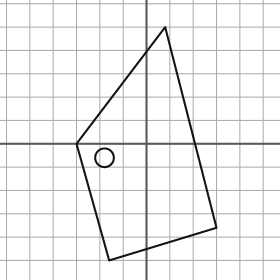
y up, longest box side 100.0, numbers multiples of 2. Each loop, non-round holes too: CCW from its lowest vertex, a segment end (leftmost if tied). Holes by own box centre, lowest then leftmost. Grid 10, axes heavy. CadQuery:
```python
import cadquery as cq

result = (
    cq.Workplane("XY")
    .moveTo(-16.0, -50.0)
    .lineTo(30.0, -36.0)
    .lineTo(8.0, 50.0)
    .lineTo(-30.0, 0.0)
    .close()
    .moveTo(-18.0, -6.0)
    .circle(4.0)
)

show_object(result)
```